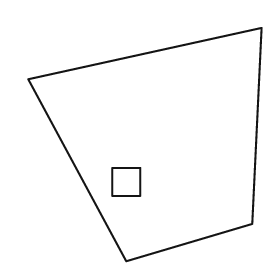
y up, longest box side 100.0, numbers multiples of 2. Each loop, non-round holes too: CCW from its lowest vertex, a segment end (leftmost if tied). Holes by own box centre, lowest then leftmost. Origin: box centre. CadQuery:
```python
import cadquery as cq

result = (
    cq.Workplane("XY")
    .moveTo(-8.0, -50.0)
    .lineTo(46.0, -34.0)
    .lineTo(50.0, 50.0)
    .lineTo(-50.0, 28.0)
    .close()
    .moveTo(-14.0, -22.0)
    .lineTo(-2.0, -22.0)
    .lineTo(-2.0, -10.0)
    .lineTo(-14.0, -10.0)
    .close()
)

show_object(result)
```